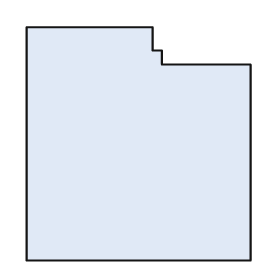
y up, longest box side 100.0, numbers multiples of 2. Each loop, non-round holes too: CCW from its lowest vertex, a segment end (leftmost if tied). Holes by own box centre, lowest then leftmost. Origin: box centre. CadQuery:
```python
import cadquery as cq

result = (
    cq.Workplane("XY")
    .moveTo(-48.0, -50.0)
    .lineTo(48.0, -50.0)
    .lineTo(48.0, 34.0)
    .lineTo(10.0, 34.0)
    .lineTo(10.0, 40.0)
    .lineTo(6.0, 40.0)
    .lineTo(6.0, 50.0)
    .lineTo(-48.0, 50.0)
    .close()
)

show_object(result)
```